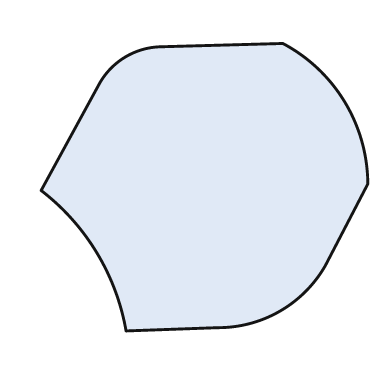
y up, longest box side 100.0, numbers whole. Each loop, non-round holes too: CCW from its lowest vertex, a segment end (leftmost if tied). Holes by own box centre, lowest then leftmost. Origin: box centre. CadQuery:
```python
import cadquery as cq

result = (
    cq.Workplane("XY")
    .moveTo(-24.0, -44.0)
    .lineTo(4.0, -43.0)
    .threePointArc((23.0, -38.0), (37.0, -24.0))
    .lineTo(50.0, 1.0)
    .threePointArc((43.0, 26.0), (24.0, 44.0))
    .lineTo(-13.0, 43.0)
    .threePointArc((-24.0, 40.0), (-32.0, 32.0))
    .lineTo(-50.0, -1.0)
    .threePointArc((-33.0, -20.0), (-24.0, -44.0))
    .close()
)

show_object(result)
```